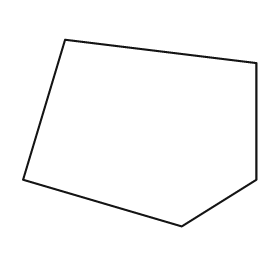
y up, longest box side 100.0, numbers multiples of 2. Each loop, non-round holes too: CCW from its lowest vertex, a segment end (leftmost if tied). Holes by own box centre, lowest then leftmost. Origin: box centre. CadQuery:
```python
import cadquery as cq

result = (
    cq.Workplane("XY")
    .moveTo(18.0, -40.0)
    .lineTo(50.0, -20.0)
    .lineTo(50.0, 30.0)
    .lineTo(-32.0, 40.0)
    .lineTo(-50.0, -20.0)
    .close()
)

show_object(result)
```